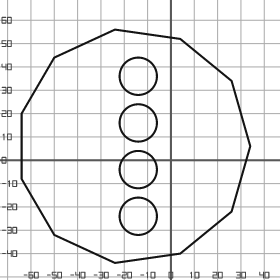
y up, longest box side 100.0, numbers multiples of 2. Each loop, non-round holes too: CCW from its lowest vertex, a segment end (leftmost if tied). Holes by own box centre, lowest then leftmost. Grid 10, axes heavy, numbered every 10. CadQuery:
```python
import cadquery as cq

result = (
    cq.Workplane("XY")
    .moveTo(-24.0, -44.0)
    .lineTo(4.0, -40.0)
    .lineTo(26.0, -22.0)
    .lineTo(34.0, 6.0)
    .lineTo(26.0, 34.0)
    .lineTo(4.0, 52.0)
    .lineTo(-24.0, 56.0)
    .lineTo(-50.0, 44.0)
    .lineTo(-64.0, 20.0)
    .lineTo(-64.0, -8.0)
    .lineTo(-50.0, -32.0)
    .close()
    .moveTo(-14.0, -24.0)
    .circle(8.0)
    .moveTo(-14.0, -4.0)
    .circle(8.0)
    .moveTo(-14.0, 16.0)
    .circle(8.0)
    .moveTo(-14.0, 36.0)
    .circle(8.0)
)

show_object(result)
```